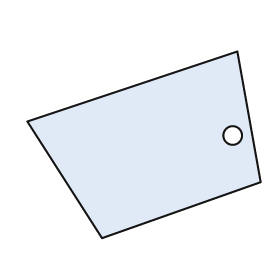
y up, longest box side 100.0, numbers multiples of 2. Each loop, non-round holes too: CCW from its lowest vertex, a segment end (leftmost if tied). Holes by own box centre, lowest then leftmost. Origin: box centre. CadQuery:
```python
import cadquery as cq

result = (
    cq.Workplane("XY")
    .moveTo(-18.0, -40.0)
    .lineTo(50.0, -16.0)
    .lineTo(40.0, 40.0)
    .lineTo(-50.0, 10.0)
    .close()
    .moveTo(38.0, 4.0)
    .circle(4.0)
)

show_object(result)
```